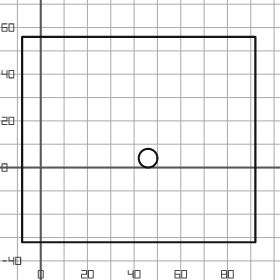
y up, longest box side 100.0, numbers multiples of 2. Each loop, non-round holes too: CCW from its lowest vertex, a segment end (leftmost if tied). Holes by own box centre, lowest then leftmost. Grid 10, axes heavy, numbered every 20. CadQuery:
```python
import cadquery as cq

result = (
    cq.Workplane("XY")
    .moveTo(-8.0, -32.0)
    .lineTo(92.0, -32.0)
    .lineTo(92.0, 56.0)
    .lineTo(-8.0, 56.0)
    .close()
    .moveTo(46.0, 4.0)
    .circle(4.0)
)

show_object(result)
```